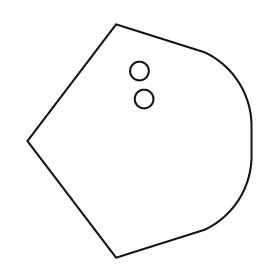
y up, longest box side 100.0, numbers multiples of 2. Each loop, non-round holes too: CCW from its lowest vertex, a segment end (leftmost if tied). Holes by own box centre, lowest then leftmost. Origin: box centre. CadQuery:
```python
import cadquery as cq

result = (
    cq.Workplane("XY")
    .moveTo(-10.0, -50.0)
    .lineTo(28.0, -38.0)
    .threePointArc((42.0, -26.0), (48.0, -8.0))
    .lineTo(48.0, 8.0)
    .threePointArc((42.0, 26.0), (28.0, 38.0))
    .lineTo(-10.0, 50.0)
    .lineTo(-48.0, 0.0)
    .close()
    .moveTo(2.0, 18.0)
    .circle(4.0)
    .moveTo(0.0, 30.0)
    .circle(4.0)
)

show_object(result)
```